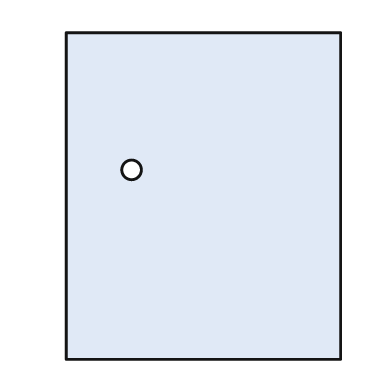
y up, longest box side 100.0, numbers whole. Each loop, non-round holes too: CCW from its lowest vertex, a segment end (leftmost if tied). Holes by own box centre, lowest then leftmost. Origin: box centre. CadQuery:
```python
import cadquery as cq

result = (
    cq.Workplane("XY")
    .moveTo(-42.0, -50.0)
    .lineTo(42.0, -50.0)
    .lineTo(42.0, 50.0)
    .lineTo(-42.0, 50.0)
    .close()
    .moveTo(-22.0, 8.0)
    .circle(3.0)
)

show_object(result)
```